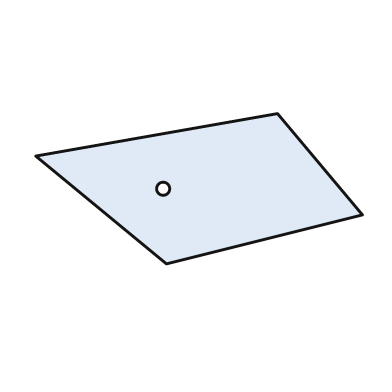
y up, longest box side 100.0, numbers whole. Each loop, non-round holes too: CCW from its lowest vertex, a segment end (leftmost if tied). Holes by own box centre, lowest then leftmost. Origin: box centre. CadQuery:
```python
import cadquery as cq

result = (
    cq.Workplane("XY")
    .moveTo(-10.0, -23.0)
    .lineTo(50.0, -8.0)
    .lineTo(24.0, 23.0)
    .lineTo(-50.0, 10.0)
    .close()
    .moveTo(-11.0, 0.0)
    .circle(2.0)
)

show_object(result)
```